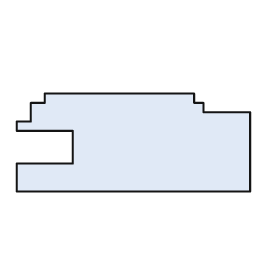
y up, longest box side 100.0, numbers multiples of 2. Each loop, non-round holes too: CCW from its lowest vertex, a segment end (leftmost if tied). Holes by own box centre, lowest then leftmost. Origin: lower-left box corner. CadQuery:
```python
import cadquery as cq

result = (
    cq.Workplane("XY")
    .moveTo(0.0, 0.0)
    .lineTo(100.0, 0.0)
    .lineTo(100.0, 34.0)
    .lineTo(80.0, 34.0)
    .lineTo(80.0, 38.0)
    .lineTo(76.0, 38.0)
    .lineTo(76.0, 42.0)
    .lineTo(12.0, 42.0)
    .lineTo(12.0, 38.0)
    .lineTo(6.0, 38.0)
    .lineTo(6.0, 30.0)
    .lineTo(0.0, 30.0)
    .lineTo(0.0, 26.0)
    .lineTo(24.0, 26.0)
    .lineTo(24.0, 12.0)
    .lineTo(0.0, 12.0)
    .close()
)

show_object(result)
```